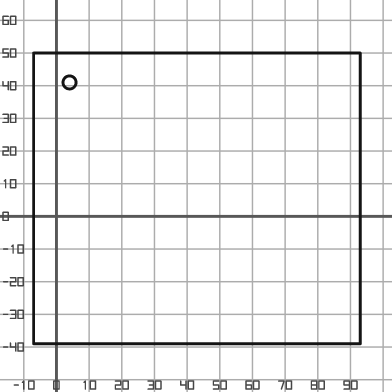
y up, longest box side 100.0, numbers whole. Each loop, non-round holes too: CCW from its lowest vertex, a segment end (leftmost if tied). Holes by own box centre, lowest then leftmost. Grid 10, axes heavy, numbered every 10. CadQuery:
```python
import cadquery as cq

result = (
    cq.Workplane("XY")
    .moveTo(-7.0, -39.0)
    .lineTo(93.0, -39.0)
    .lineTo(93.0, 50.0)
    .lineTo(-7.0, 50.0)
    .close()
    .moveTo(4.0, 41.0)
    .circle(2.0)
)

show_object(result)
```